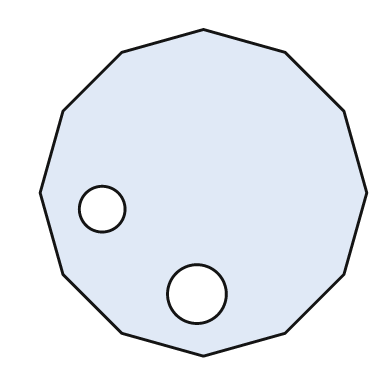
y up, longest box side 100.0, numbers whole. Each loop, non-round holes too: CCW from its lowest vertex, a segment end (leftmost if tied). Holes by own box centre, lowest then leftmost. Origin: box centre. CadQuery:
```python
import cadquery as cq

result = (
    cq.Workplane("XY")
    .moveTo(0.0, -50.0)
    .lineTo(25.0, -43.0)
    .lineTo(43.0, -25.0)
    .lineTo(50.0, 0.0)
    .lineTo(43.0, 25.0)
    .lineTo(25.0, 43.0)
    .lineTo(0.0, 50.0)
    .lineTo(-25.0, 43.0)
    .lineTo(-43.0, 25.0)
    .lineTo(-50.0, 0.0)
    .lineTo(-43.0, -25.0)
    .lineTo(-25.0, -43.0)
    .close()
    .moveTo(-2.0, -31.0)
    .circle(9.0)
    .moveTo(-31.0, -5.0)
    .circle(7.0)
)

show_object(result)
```